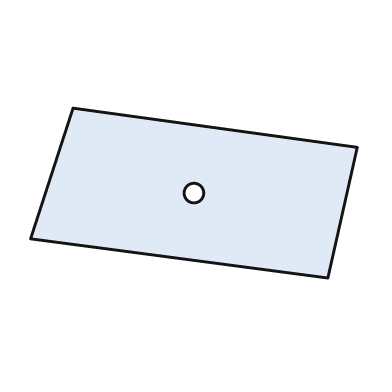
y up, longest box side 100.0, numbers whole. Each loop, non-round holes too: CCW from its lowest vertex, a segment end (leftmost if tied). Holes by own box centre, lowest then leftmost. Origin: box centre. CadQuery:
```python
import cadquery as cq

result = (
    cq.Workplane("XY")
    .moveTo(41.0, -26.0)
    .lineTo(50.0, 14.0)
    .lineTo(-37.0, 26.0)
    .lineTo(-50.0, -14.0)
    .close()
    .moveTo(0.0, 0.0)
    .circle(3.0)
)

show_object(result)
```